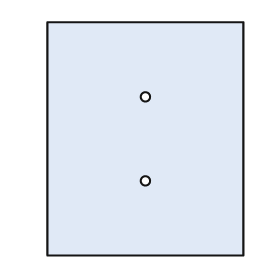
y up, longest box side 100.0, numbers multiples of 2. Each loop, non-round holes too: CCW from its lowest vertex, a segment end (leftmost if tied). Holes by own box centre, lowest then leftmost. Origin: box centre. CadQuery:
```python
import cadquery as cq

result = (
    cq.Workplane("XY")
    .moveTo(-42.0, -50.0)
    .lineTo(42.0, -50.0)
    .lineTo(42.0, 50.0)
    .lineTo(-42.0, 50.0)
    .close()
    .moveTo(0.0, -18.0)
    .circle(2.0)
    .moveTo(0.0, 18.0)
    .circle(2.0)
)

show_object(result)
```